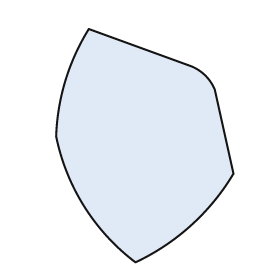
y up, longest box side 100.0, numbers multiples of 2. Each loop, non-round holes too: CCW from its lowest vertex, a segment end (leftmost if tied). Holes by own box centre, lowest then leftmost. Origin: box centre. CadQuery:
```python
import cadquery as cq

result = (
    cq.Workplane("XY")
    .moveTo(-4.0, -50.0)
    .threePointArc((20.0, -34.0), (38.0, -12.0))
    .lineTo(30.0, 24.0)
    .threePointArc((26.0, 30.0), (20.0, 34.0))
    .lineTo(-24.0, 50.0)
    .threePointArc((-34.0, 28.0), (-38.0, 4.0))
    .threePointArc((-26.0, -26.0), (-4.0, -50.0))
    .close()
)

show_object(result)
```